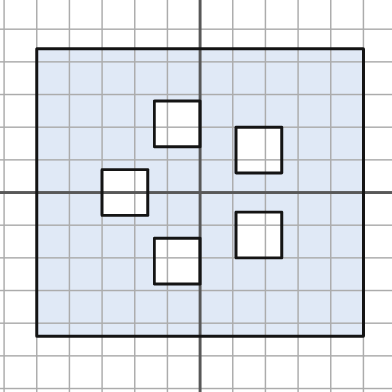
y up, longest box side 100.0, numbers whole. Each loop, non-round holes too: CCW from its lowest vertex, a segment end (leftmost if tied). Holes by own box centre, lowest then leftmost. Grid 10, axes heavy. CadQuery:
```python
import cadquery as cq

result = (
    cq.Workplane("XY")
    .moveTo(-50.0, -44.0)
    .lineTo(50.0, -44.0)
    .lineTo(50.0, 44.0)
    .lineTo(-50.0, 44.0)
    .close()
    .moveTo(-14.0, -28.0)
    .lineTo(0.0, -28.0)
    .lineTo(0.0, -14.0)
    .lineTo(-14.0, -14.0)
    .close()
    .moveTo(11.0, -20.0)
    .lineTo(25.0, -20.0)
    .lineTo(25.0, -6.0)
    .lineTo(11.0, -6.0)
    .close()
    .moveTo(-30.0, -7.0)
    .lineTo(-16.0, -7.0)
    .lineTo(-16.0, 7.0)
    .lineTo(-30.0, 7.0)
    .close()
    .moveTo(11.0, 6.0)
    .lineTo(25.0, 6.0)
    .lineTo(25.0, 20.0)
    .lineTo(11.0, 20.0)
    .close()
    .moveTo(-14.0, 14.0)
    .lineTo(0.0, 14.0)
    .lineTo(0.0, 28.0)
    .lineTo(-14.0, 28.0)
    .close()
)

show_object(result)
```